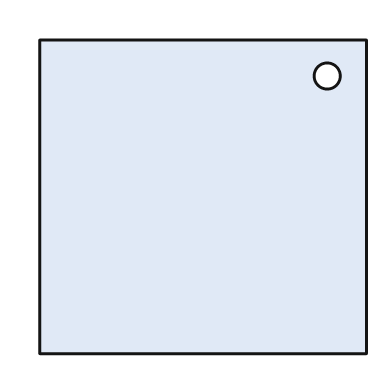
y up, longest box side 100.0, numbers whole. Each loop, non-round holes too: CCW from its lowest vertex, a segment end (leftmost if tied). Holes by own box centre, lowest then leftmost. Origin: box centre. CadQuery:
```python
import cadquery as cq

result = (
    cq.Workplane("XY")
    .moveTo(-50.0, -48.0)
    .lineTo(50.0, -48.0)
    .lineTo(50.0, 48.0)
    .lineTo(-50.0, 48.0)
    .close()
    .moveTo(38.0, 37.0)
    .circle(4.0)
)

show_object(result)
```